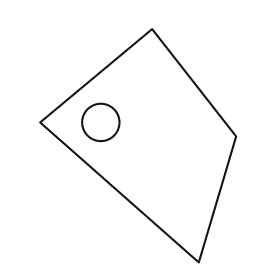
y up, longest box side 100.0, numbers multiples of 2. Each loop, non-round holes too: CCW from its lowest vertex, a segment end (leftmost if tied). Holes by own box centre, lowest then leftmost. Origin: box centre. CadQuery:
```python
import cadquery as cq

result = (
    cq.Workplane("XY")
    .moveTo(26.0, -50.0)
    .lineTo(42.0, 4.0)
    .lineTo(6.0, 50.0)
    .lineTo(-42.0, 10.0)
    .close()
    .moveTo(-16.0, 10.0)
    .circle(8.0)
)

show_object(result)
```